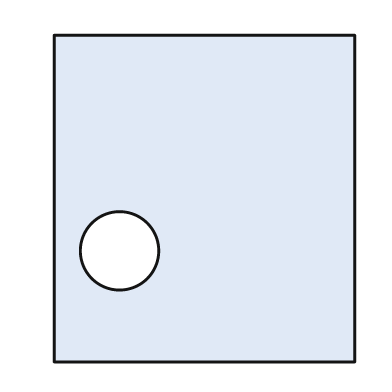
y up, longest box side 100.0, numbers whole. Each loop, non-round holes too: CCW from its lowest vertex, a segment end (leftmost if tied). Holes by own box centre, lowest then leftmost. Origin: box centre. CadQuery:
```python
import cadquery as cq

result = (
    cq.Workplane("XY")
    .moveTo(-46.0, -50.0)
    .lineTo(46.0, -50.0)
    .lineTo(46.0, 50.0)
    .lineTo(-46.0, 50.0)
    .close()
    .moveTo(-26.0, -16.0)
    .circle(12.0)
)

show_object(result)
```